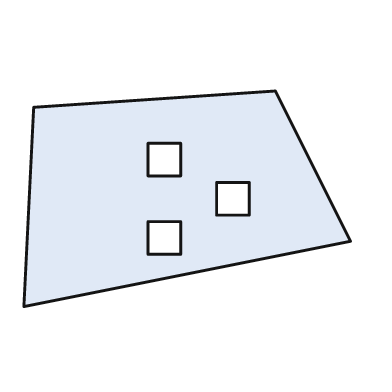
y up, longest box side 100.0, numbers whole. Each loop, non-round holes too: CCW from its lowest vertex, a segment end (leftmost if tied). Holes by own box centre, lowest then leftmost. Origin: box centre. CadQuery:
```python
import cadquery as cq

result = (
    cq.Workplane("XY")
    .moveTo(-50.0, -33.0)
    .lineTo(50.0, -13.0)
    .lineTo(27.0, 33.0)
    .lineTo(-47.0, 28.0)
    .close()
    .moveTo(-12.0, -17.0)
    .lineTo(-2.0, -17.0)
    .lineTo(-2.0, -7.0)
    .lineTo(-12.0, -7.0)
    .close()
    .moveTo(9.0, -5.0)
    .lineTo(19.0, -5.0)
    .lineTo(19.0, 5.0)
    .lineTo(9.0, 5.0)
    .close()
    .moveTo(-12.0, 7.0)
    .lineTo(-2.0, 7.0)
    .lineTo(-2.0, 17.0)
    .lineTo(-12.0, 17.0)
    .close()
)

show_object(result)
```